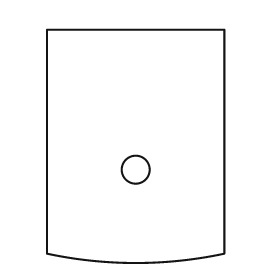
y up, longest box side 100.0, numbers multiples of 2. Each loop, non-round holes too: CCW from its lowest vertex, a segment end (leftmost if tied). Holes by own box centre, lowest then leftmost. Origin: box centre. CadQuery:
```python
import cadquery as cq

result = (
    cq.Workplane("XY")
    .moveTo(-38.0, -46.0)
    .threePointArc((0.0, -50.0), (38.0, -46.0))
    .lineTo(38.0, 50.0)
    .lineTo(-38.0, 50.0)
    .close()
    .moveTo(0.0, -10.0)
    .circle(6.0)
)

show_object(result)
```